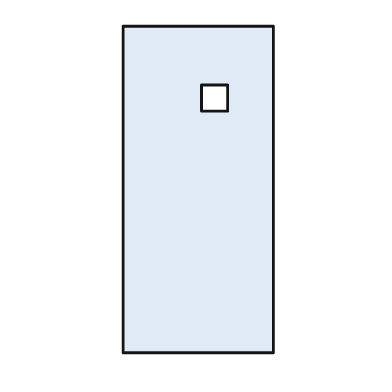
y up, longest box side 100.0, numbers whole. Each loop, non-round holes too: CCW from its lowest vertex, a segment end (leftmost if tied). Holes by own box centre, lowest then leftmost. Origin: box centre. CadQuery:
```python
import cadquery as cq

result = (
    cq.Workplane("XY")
    .moveTo(-23.0, -50.0)
    .lineTo(23.0, -50.0)
    .lineTo(23.0, 50.0)
    .lineTo(-23.0, 50.0)
    .close()
    .moveTo(1.0, 24.0)
    .lineTo(9.0, 24.0)
    .lineTo(9.0, 32.0)
    .lineTo(1.0, 32.0)
    .close()
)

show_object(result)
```